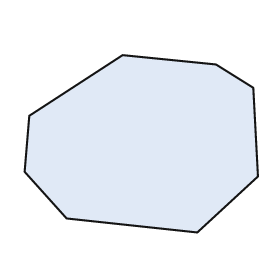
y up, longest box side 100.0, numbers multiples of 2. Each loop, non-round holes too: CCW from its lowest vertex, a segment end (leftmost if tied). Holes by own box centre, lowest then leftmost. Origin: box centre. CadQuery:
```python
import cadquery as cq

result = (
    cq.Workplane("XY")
    .moveTo(24.0, -38.0)
    .lineTo(50.0, -14.0)
    .lineTo(48.0, 24.0)
    .lineTo(32.0, 34.0)
    .lineTo(-8.0, 38.0)
    .lineTo(-48.0, 12.0)
    .lineTo(-50.0, -12.0)
    .lineTo(-32.0, -32.0)
    .close()
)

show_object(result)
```